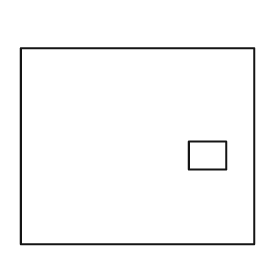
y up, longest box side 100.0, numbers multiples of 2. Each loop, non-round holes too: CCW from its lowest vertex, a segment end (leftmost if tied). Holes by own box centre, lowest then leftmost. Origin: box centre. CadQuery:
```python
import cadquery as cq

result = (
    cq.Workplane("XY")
    .moveTo(-50.0, -42.0)
    .lineTo(50.0, -42.0)
    .lineTo(50.0, 42.0)
    .lineTo(-50.0, 42.0)
    .close()
    .moveTo(22.0, -10.0)
    .lineTo(38.0, -10.0)
    .lineTo(38.0, 2.0)
    .lineTo(22.0, 2.0)
    .close()
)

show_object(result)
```